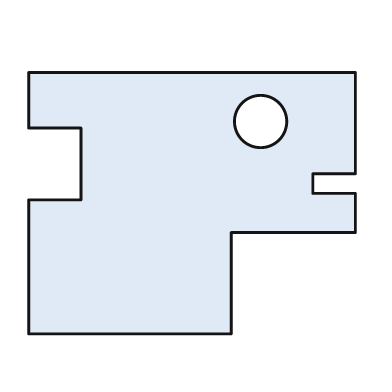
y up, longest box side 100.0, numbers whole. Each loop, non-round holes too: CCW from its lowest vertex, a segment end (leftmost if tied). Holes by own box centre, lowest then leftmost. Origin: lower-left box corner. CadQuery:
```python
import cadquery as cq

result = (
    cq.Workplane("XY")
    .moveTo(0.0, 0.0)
    .lineTo(62.0, 0.0)
    .lineTo(62.0, 31.0)
    .lineTo(100.0, 31.0)
    .lineTo(100.0, 43.0)
    .lineTo(87.0, 43.0)
    .lineTo(87.0, 49.0)
    .lineTo(100.0, 49.0)
    .lineTo(100.0, 80.0)
    .lineTo(0.0, 80.0)
    .lineTo(0.0, 63.0)
    .lineTo(16.0, 63.0)
    .lineTo(16.0, 41.0)
    .lineTo(0.0, 41.0)
    .close()
    .moveTo(71.0, 65.0)
    .circle(8.0)
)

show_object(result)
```